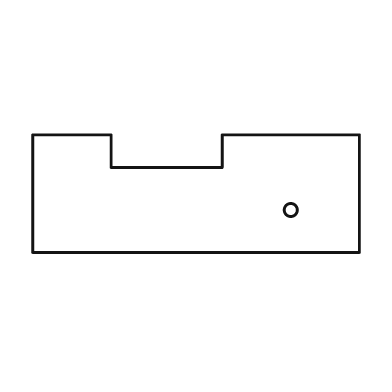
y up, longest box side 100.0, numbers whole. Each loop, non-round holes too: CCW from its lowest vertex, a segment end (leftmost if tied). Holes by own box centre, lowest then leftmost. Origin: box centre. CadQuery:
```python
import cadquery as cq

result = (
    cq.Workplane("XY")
    .moveTo(-50.0, -18.0)
    .lineTo(50.0, -18.0)
    .lineTo(50.0, 18.0)
    .lineTo(8.0, 18.0)
    .lineTo(8.0, 8.0)
    .lineTo(-26.0, 8.0)
    .lineTo(-26.0, 18.0)
    .lineTo(-50.0, 18.0)
    .close()
    .moveTo(29.0, -5.0)
    .circle(2.0)
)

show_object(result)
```